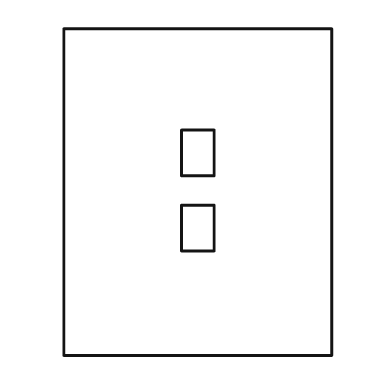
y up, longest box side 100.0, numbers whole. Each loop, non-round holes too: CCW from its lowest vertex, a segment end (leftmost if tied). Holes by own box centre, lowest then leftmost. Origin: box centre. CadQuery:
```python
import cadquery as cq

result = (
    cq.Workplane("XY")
    .moveTo(-41.0, -50.0)
    .lineTo(41.0, -50.0)
    .lineTo(41.0, 50.0)
    .lineTo(-41.0, 50.0)
    .close()
    .moveTo(-5.0, -18.0)
    .lineTo(5.0, -18.0)
    .lineTo(5.0, -4.0)
    .lineTo(-5.0, -4.0)
    .close()
    .moveTo(-5.0, 5.0)
    .lineTo(5.0, 5.0)
    .lineTo(5.0, 19.0)
    .lineTo(-5.0, 19.0)
    .close()
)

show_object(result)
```